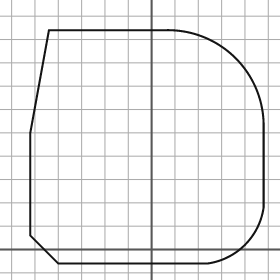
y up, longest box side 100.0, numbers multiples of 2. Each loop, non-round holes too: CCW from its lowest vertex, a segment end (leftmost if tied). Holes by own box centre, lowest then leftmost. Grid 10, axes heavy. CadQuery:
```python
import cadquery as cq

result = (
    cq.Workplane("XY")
    .moveTo(-40.0, -6.0)
    .lineTo(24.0, -6.0)
    .threePointArc((40.0, 2.0), (48.0, 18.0))
    .lineTo(48.0, 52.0)
    .threePointArc((36.0, 82.0), (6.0, 94.0))
    .lineTo(-44.0, 94.0)
    .lineTo(-52.0, 50.0)
    .lineTo(-52.0, 6.0)
    .close()
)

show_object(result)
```